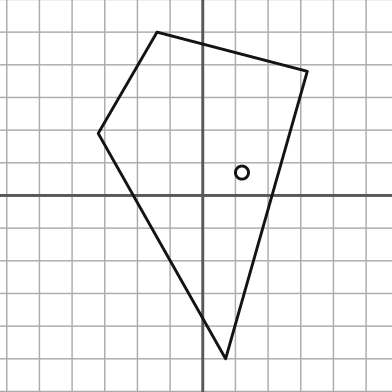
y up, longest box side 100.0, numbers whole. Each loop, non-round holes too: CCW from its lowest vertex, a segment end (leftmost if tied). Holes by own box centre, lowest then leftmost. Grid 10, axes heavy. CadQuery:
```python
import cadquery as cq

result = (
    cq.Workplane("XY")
    .moveTo(7.0, -50.0)
    .lineTo(32.0, 38.0)
    .lineTo(-14.0, 50.0)
    .lineTo(-32.0, 19.0)
    .close()
    .moveTo(12.0, 7.0)
    .circle(2.0)
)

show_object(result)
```